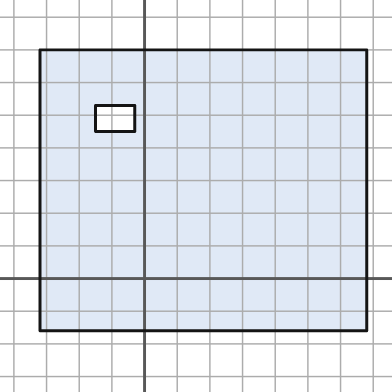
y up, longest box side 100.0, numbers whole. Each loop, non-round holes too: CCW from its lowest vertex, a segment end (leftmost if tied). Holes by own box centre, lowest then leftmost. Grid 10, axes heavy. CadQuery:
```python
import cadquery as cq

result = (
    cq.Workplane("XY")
    .moveTo(-32.0, -16.0)
    .lineTo(68.0, -16.0)
    .lineTo(68.0, 70.0)
    .lineTo(-32.0, 70.0)
    .close()
    .moveTo(-15.0, 45.0)
    .lineTo(-3.0, 45.0)
    .lineTo(-3.0, 53.0)
    .lineTo(-15.0, 53.0)
    .close()
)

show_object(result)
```